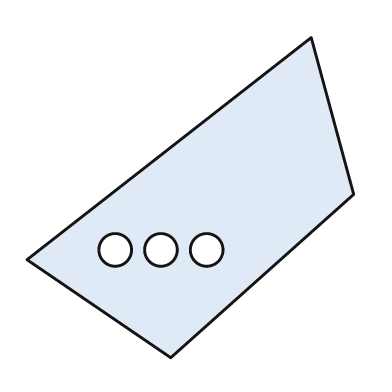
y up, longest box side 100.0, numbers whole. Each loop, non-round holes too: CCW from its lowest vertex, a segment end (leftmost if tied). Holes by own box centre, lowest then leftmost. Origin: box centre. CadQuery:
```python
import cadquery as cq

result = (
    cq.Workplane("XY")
    .moveTo(-6.0, -49.0)
    .lineTo(50.0, 1.0)
    .lineTo(37.0, 49.0)
    .lineTo(-50.0, -19.0)
    .close()
    .moveTo(-23.0, -16.0)
    .circle(5.0)
    .moveTo(-9.0, -16.0)
    .circle(5.0)
    .moveTo(5.0, -16.0)
    .circle(5.0)
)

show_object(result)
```